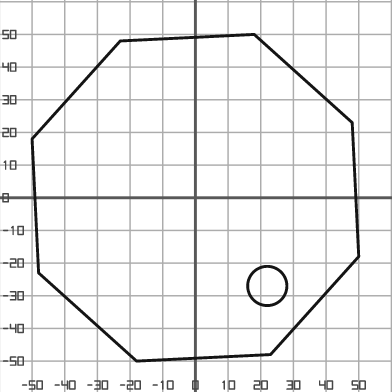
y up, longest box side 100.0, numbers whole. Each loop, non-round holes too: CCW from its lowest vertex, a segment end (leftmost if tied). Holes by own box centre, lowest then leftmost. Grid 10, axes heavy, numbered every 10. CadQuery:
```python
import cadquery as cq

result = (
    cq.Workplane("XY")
    .moveTo(-18.0, -50.0)
    .lineTo(23.0, -48.0)
    .lineTo(50.0, -18.0)
    .lineTo(48.0, 23.0)
    .lineTo(18.0, 50.0)
    .lineTo(-23.0, 48.0)
    .lineTo(-50.0, 18.0)
    .lineTo(-48.0, -23.0)
    .close()
    .moveTo(22.0, -27.0)
    .circle(6.0)
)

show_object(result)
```